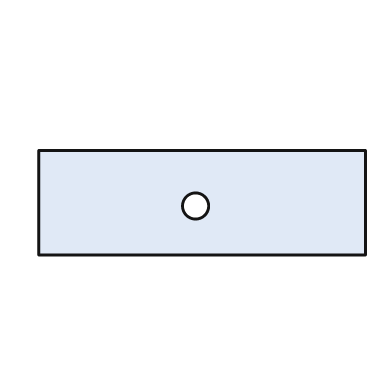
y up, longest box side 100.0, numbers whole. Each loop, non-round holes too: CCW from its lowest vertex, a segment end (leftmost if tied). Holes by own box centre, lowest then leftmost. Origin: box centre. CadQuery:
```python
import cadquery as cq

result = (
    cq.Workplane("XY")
    .moveTo(-50.0, -16.0)
    .lineTo(50.0, -16.0)
    .lineTo(50.0, 16.0)
    .lineTo(-50.0, 16.0)
    .close()
    .moveTo(-2.0, -1.0)
    .circle(4.0)
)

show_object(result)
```